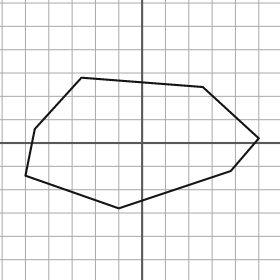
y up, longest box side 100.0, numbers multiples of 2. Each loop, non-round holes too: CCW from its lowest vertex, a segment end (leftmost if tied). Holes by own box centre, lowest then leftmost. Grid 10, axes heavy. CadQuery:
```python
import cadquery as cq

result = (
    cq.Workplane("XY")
    .moveTo(-10.0, -28.0)
    .lineTo(38.0, -12.0)
    .lineTo(50.0, 2.0)
    .lineTo(26.0, 24.0)
    .lineTo(-26.0, 28.0)
    .lineTo(-46.0, 6.0)
    .lineTo(-50.0, -14.0)
    .close()
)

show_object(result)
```